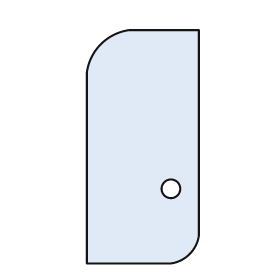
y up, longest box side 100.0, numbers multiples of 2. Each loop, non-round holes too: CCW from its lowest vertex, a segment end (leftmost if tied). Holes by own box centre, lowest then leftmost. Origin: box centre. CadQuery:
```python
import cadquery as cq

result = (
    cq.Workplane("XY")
    .moveTo(-24.0, -50.0)
    .lineTo(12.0, -50.0)
    .threePointArc((20.0, -46.0), (24.0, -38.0))
    .lineTo(24.0, 50.0)
    .lineTo(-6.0, 50.0)
    .threePointArc((-18.0, 44.0), (-24.0, 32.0))
    .close()
    .moveTo(12.0, -18.0)
    .circle(4.0)
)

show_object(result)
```